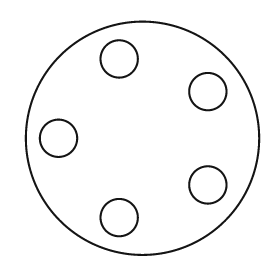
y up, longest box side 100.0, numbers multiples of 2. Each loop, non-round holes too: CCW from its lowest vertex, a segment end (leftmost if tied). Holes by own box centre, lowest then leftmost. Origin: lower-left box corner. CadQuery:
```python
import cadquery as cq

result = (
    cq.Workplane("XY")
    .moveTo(50.0, 50.0)
    .circle(50.0)
    .moveTo(40.0, 16.0)
    .circle(8.0)
    .moveTo(78.0, 30.0)
    .circle(8.0)
    .moveTo(14.0, 50.0)
    .circle(8.0)
    .moveTo(78.0, 70.0)
    .circle(8.0)
    .moveTo(40.0, 84.0)
    .circle(8.0)
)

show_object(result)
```